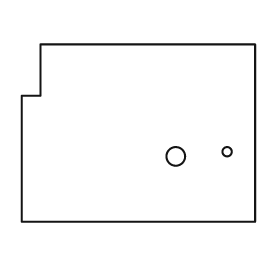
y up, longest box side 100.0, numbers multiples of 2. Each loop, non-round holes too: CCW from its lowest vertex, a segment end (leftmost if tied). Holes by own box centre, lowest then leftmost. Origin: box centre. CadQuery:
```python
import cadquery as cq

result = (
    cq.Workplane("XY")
    .moveTo(-50.0, -38.0)
    .lineTo(50.0, -38.0)
    .lineTo(50.0, 38.0)
    .lineTo(-42.0, 38.0)
    .lineTo(-42.0, 16.0)
    .lineTo(-50.0, 16.0)
    .close()
    .moveTo(16.0, -10.0)
    .circle(4.0)
    .moveTo(38.0, -8.0)
    .circle(2.0)
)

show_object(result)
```